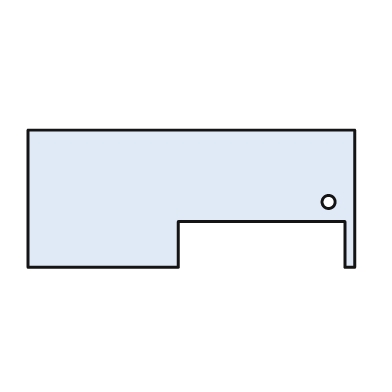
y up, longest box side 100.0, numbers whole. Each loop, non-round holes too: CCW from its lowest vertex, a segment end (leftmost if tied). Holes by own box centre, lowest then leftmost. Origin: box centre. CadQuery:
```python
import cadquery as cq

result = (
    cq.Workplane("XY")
    .moveTo(-50.0, -21.0)
    .lineTo(-4.0, -21.0)
    .lineTo(-4.0, -7.0)
    .lineTo(47.0, -7.0)
    .lineTo(47.0, -21.0)
    .lineTo(50.0, -21.0)
    .lineTo(50.0, 21.0)
    .lineTo(-50.0, 21.0)
    .close()
    .moveTo(42.0, -1.0)
    .circle(2.0)
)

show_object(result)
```